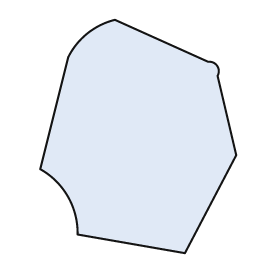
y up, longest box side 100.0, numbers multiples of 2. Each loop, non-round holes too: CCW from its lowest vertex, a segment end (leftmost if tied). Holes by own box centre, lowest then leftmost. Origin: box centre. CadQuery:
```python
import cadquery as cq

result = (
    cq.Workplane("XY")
    .moveTo(20.0, -50.0)
    .lineTo(42.0, -8.0)
    .lineTo(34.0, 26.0)
    .threePointArc((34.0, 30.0), (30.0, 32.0))
    .lineTo(-10.0, 50.0)
    .threePointArc((-22.0, 44.0), (-30.0, 34.0))
    .lineTo(-42.0, -14.0)
    .threePointArc((-30.0, -26.0), (-26.0, -42.0))
    .close()
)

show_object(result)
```